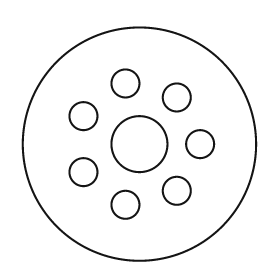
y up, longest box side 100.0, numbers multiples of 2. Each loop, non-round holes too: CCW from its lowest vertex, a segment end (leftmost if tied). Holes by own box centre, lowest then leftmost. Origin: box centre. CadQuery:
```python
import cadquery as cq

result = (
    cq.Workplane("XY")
    .moveTo(0.0, 0.0)
    .circle(50.0)
    .moveTo(-6.0, -26.0)
    .circle(6.0)
    .moveTo(16.0, -20.0)
    .circle(6.0)
    .moveTo(-24.0, -12.0)
    .circle(6.0)
    .moveTo(0.0, 0.0)
    .circle(12.0)
    .moveTo(26.0, 0.0)
    .circle(6.0)
    .moveTo(-24.0, 12.0)
    .circle(6.0)
    .moveTo(16.0, 20.0)
    .circle(6.0)
    .moveTo(-6.0, 26.0)
    .circle(6.0)
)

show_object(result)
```